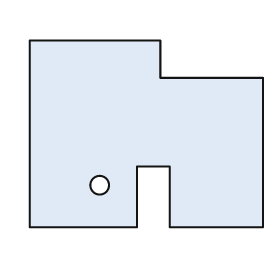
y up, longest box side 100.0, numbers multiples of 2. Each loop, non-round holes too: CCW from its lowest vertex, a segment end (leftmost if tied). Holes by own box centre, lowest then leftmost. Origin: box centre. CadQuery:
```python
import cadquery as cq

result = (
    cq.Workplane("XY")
    .moveTo(-50.0, -40.0)
    .lineTo(-4.0, -40.0)
    .lineTo(-4.0, -14.0)
    .lineTo(10.0, -14.0)
    .lineTo(10.0, -40.0)
    .lineTo(50.0, -40.0)
    .lineTo(50.0, 24.0)
    .lineTo(6.0, 24.0)
    .lineTo(6.0, 40.0)
    .lineTo(-50.0, 40.0)
    .close()
    .moveTo(-20.0, -22.0)
    .circle(4.0)
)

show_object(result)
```